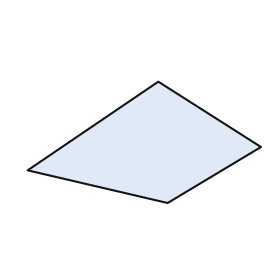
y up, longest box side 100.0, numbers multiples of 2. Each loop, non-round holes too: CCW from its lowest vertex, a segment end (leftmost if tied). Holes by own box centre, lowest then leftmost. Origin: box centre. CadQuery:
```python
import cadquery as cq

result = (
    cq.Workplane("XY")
    .moveTo(10.0, -26.0)
    .lineTo(50.0, -2.0)
    .lineTo(6.0, 26.0)
    .lineTo(-50.0, -12.0)
    .close()
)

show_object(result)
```